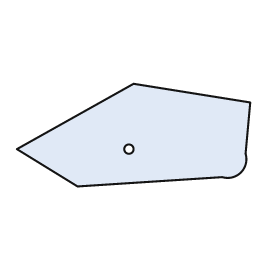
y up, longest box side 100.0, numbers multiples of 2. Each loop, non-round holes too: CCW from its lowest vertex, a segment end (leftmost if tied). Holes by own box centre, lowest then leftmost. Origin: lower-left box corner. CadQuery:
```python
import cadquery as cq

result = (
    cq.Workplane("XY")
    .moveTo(26.0, 0.0)
    .lineTo(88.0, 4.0)
    .threePointArc((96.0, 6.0), (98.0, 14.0))
    .lineTo(100.0, 36.0)
    .lineTo(50.0, 44.0)
    .lineTo(0.0, 16.0)
    .close()
    .moveTo(48.0, 16.0)
    .circle(2.0)
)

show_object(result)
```